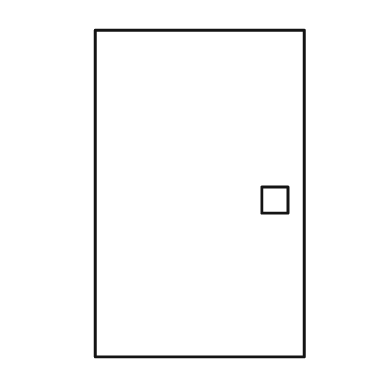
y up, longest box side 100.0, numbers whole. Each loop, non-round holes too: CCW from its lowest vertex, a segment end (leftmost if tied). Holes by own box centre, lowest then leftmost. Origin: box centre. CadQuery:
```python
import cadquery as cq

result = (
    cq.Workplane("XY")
    .moveTo(-32.0, -50.0)
    .lineTo(32.0, -50.0)
    .lineTo(32.0, 50.0)
    .lineTo(-32.0, 50.0)
    .close()
    .moveTo(19.0, -6.0)
    .lineTo(27.0, -6.0)
    .lineTo(27.0, 2.0)
    .lineTo(19.0, 2.0)
    .close()
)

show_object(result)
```